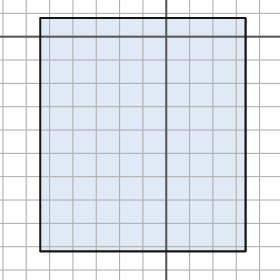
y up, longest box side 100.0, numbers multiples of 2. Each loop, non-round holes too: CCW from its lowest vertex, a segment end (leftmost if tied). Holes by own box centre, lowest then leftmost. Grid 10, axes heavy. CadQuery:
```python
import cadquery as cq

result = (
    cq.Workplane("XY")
    .moveTo(-54.0, -92.0)
    .lineTo(34.0, -92.0)
    .lineTo(34.0, 8.0)
    .lineTo(-54.0, 8.0)
    .close()
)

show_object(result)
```